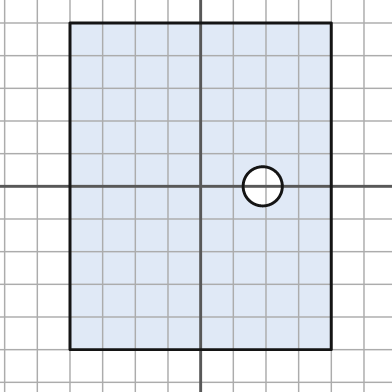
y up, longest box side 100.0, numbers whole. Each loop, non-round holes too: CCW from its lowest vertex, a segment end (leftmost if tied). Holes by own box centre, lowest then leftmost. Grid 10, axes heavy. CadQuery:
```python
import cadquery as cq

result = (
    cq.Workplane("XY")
    .moveTo(-40.0, -50.0)
    .lineTo(40.0, -50.0)
    .lineTo(40.0, 50.0)
    .lineTo(-40.0, 50.0)
    .close()
    .moveTo(19.0, 0.0)
    .circle(6.0)
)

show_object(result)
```